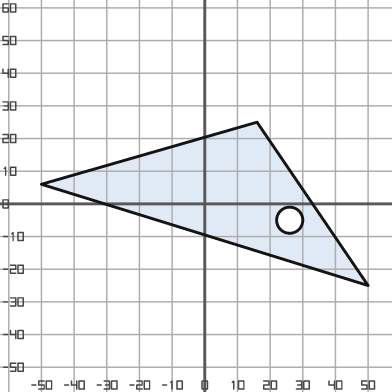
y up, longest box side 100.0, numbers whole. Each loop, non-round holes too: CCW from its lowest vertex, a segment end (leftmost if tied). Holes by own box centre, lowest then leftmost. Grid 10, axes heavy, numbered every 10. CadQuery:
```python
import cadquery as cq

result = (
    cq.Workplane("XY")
    .moveTo(50.0, -25.0)
    .lineTo(16.0, 25.0)
    .lineTo(-50.0, 6.0)
    .close()
    .moveTo(26.0, -5.0)
    .circle(4.0)
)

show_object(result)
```